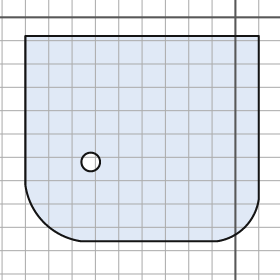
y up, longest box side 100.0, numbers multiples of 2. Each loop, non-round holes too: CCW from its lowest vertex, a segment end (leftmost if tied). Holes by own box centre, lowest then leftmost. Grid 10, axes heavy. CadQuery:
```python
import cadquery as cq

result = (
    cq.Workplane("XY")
    .moveTo(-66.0, -96.0)
    .lineTo(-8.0, -96.0)
    .threePointArc((4.0, -90.0), (10.0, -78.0))
    .lineTo(10.0, -8.0)
    .lineTo(-90.0, -8.0)
    .lineTo(-90.0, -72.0)
    .threePointArc((-82.0, -88.0), (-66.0, -96.0))
    .close()
    .moveTo(-62.0, -62.0)
    .circle(4.0)
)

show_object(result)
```